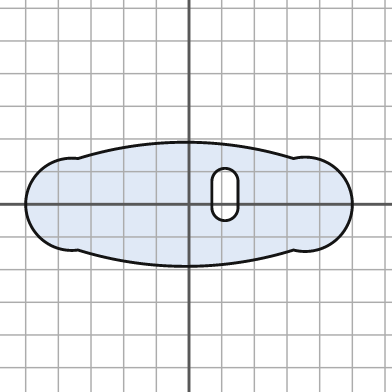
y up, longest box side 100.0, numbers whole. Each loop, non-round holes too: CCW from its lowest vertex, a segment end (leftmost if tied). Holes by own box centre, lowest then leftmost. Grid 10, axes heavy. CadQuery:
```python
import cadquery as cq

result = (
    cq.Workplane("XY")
    .moveTo(-34.0, -14.0)
    .threePointArc((-1.0, -19.0), (32.0, -14.0))
    .threePointArc((50.0, 0.0), (32.0, 14.0))
    .threePointArc((-1.0, 19.0), (-34.0, 14.0))
    .threePointArc((-50.0, 0.0), (-34.0, -14.0))
    .close()
    .moveTo(7.0, -1.0)
    .threePointArc((11.0, -5.0), (15.0, -1.0))
    .lineTo(15.0, 7.0)
    .threePointArc((11.0, 11.0), (7.0, 7.0))
    .close()
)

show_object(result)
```